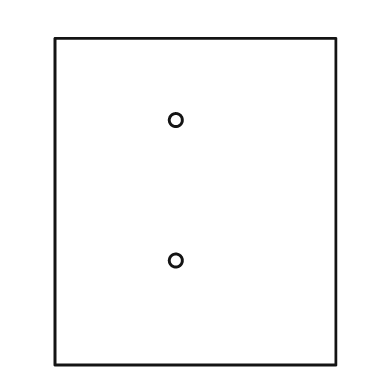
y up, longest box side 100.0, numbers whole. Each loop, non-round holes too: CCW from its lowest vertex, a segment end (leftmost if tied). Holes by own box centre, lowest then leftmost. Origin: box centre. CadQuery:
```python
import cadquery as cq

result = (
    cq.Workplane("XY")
    .moveTo(-43.0, -50.0)
    .lineTo(43.0, -50.0)
    .lineTo(43.0, 50.0)
    .lineTo(-43.0, 50.0)
    .close()
    .moveTo(-6.0, -18.0)
    .circle(2.0)
    .moveTo(-6.0, 25.0)
    .circle(2.0)
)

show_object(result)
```